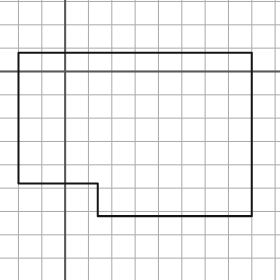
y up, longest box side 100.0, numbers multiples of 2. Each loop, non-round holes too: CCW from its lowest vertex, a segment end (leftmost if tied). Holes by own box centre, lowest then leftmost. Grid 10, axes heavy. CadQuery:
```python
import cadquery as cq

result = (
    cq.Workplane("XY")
    .moveTo(14.0, -62.0)
    .lineTo(80.0, -62.0)
    .lineTo(80.0, 8.0)
    .lineTo(-20.0, 8.0)
    .lineTo(-20.0, -48.0)
    .lineTo(14.0, -48.0)
    .close()
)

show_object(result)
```